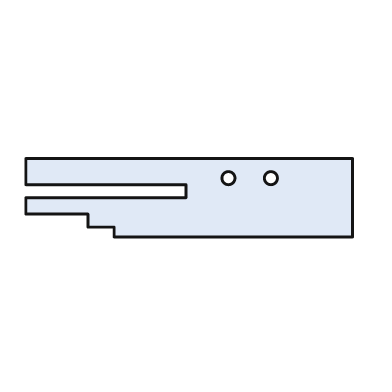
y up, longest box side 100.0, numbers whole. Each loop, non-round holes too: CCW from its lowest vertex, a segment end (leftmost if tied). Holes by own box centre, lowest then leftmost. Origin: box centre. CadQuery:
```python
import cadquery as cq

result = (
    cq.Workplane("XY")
    .moveTo(-23.0, -12.0)
    .lineTo(50.0, -12.0)
    .lineTo(50.0, 12.0)
    .lineTo(-50.0, 12.0)
    .lineTo(-50.0, 4.0)
    .lineTo(-1.0, 4.0)
    .lineTo(-1.0, 0.0)
    .lineTo(-50.0, 0.0)
    .lineTo(-50.0, -5.0)
    .lineTo(-31.0, -5.0)
    .lineTo(-31.0, -9.0)
    .lineTo(-23.0, -9.0)
    .close()
    .moveTo(12.0, 6.0)
    .circle(2.0)
    .moveTo(25.0, 6.0)
    .circle(2.0)
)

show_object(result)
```